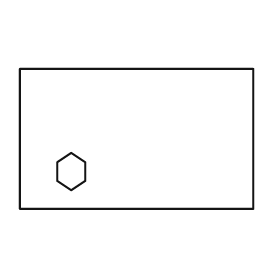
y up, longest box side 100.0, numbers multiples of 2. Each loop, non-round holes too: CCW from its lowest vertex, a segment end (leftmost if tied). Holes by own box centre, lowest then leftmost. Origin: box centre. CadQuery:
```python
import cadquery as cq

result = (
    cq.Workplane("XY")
    .moveTo(-50.0, -30.0)
    .lineTo(50.0, -30.0)
    .lineTo(50.0, 30.0)
    .lineTo(-50.0, 30.0)
    .close()
    .moveTo(-28.0, -22.0)
    .lineTo(-22.0, -18.0)
    .lineTo(-22.0, -10.0)
    .lineTo(-28.0, -6.0)
    .lineTo(-34.0, -10.0)
    .lineTo(-34.0, -18.0)
    .close()
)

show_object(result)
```